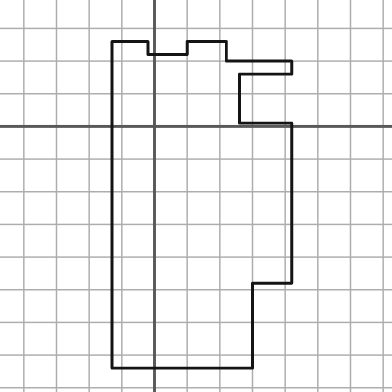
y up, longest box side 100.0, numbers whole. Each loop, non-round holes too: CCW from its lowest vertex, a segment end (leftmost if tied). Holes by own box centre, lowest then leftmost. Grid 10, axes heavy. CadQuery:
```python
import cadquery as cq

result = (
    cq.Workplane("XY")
    .moveTo(-13.0, -74.0)
    .lineTo(30.0, -74.0)
    .lineTo(30.0, -48.0)
    .lineTo(42.0, -48.0)
    .lineTo(42.0, 1.0)
    .lineTo(26.0, 1.0)
    .lineTo(26.0, 16.0)
    .lineTo(42.0, 16.0)
    .lineTo(42.0, 20.0)
    .lineTo(22.0, 20.0)
    .lineTo(22.0, 26.0)
    .lineTo(10.0, 26.0)
    .lineTo(10.0, 22.0)
    .lineTo(-2.0, 22.0)
    .lineTo(-2.0, 26.0)
    .lineTo(-13.0, 26.0)
    .close()
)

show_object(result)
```